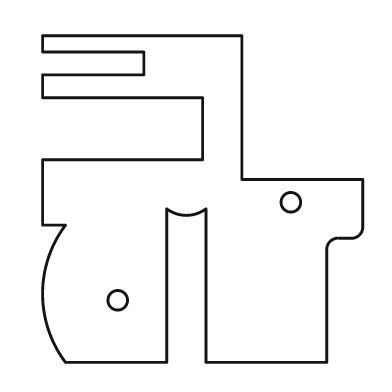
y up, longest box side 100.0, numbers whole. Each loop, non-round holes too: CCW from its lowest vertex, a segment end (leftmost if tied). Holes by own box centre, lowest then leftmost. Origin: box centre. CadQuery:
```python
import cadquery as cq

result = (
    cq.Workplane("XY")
    .moveTo(-42.0, -50.0)
    .lineTo(-11.0, -50.0)
    .lineTo(-11.0, -3.0)
    .threePointArc((-5.0, -5.0), (1.0, -3.0))
    .lineTo(1.0, -50.0)
    .lineTo(38.0, -50.0)
    .lineTo(38.0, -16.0)
    .threePointArc((39.0, -13.0), (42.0, -12.0))
    .lineTo(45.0, -12.0)
    .threePointArc((48.0, -11.0), (49.0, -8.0))
    .lineTo(49.0, 6.0)
    .lineTo(12.0, 6.0)
    .lineTo(12.0, 50.0)
    .lineTo(-49.0, 50.0)
    .lineTo(-49.0, 45.0)
    .lineTo(-18.0, 45.0)
    .lineTo(-18.0, 38.0)
    .lineTo(-49.0, 38.0)
    .lineTo(-49.0, 31.0)
    .lineTo(0.0, 31.0)
    .lineTo(0.0, 12.0)
    .lineTo(-49.0, 12.0)
    .lineTo(-49.0, -8.0)
    .lineTo(-42.0, -8.0)
    .threePointArc((-49.0, -29.0), (-42.0, -50.0))
    .close()
    .moveTo(-26.0, -31.0)
    .circle(3.0)
    .moveTo(27.0, -1.0)
    .circle(3.0)
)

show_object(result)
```